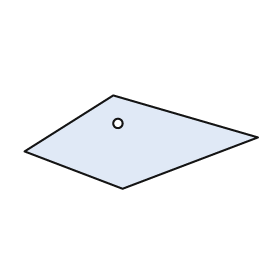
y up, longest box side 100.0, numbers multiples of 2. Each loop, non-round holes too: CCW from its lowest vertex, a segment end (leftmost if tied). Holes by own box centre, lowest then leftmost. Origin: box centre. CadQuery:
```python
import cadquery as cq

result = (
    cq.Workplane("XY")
    .moveTo(-8.0, -20.0)
    .lineTo(50.0, 2.0)
    .lineTo(-12.0, 20.0)
    .lineTo(-50.0, -4.0)
    .close()
    .moveTo(-10.0, 8.0)
    .circle(2.0)
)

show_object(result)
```